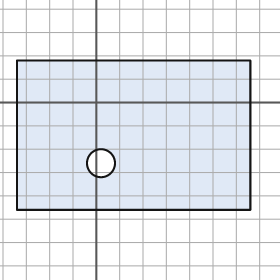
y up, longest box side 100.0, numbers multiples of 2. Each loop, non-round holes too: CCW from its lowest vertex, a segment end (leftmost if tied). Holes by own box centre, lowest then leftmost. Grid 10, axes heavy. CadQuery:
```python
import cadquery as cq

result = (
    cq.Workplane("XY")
    .moveTo(-34.0, -46.0)
    .lineTo(66.0, -46.0)
    .lineTo(66.0, 18.0)
    .lineTo(-34.0, 18.0)
    .close()
    .moveTo(2.0, -26.0)
    .circle(6.0)
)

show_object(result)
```